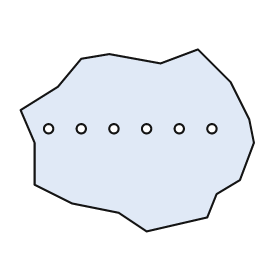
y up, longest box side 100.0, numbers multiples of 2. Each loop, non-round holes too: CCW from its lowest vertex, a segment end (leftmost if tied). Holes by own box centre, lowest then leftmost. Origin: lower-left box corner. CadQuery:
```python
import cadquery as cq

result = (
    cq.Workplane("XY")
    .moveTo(54.0, 0.0)
    .lineTo(80.0, 6.0)
    .lineTo(84.0, 16.0)
    .lineTo(94.0, 22.0)
    .lineTo(100.0, 38.0)
    .lineTo(98.0, 48.0)
    .lineTo(90.0, 64.0)
    .lineTo(76.0, 78.0)
    .lineTo(60.0, 72.0)
    .lineTo(38.0, 76.0)
    .lineTo(26.0, 74.0)
    .lineTo(16.0, 62.0)
    .lineTo(0.0, 52.0)
    .lineTo(6.0, 38.0)
    .lineTo(6.0, 20.0)
    .lineTo(22.0, 12.0)
    .lineTo(42.0, 8.0)
    .close()
    .moveTo(12.0, 44.0)
    .circle(2.0)
    .moveTo(26.0, 44.0)
    .circle(2.0)
    .moveTo(40.0, 44.0)
    .circle(2.0)
    .moveTo(54.0, 44.0)
    .circle(2.0)
    .moveTo(68.0, 44.0)
    .circle(2.0)
    .moveTo(82.0, 44.0)
    .circle(2.0)
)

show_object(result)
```